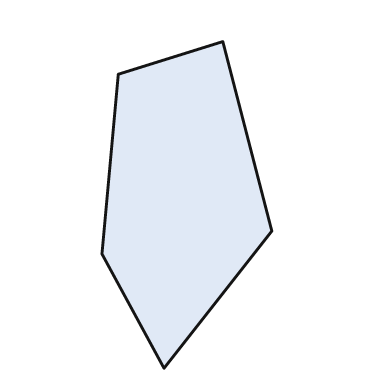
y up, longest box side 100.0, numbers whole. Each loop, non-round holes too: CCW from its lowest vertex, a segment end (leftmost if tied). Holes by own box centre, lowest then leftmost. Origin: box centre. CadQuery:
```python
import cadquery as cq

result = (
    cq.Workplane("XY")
    .moveTo(-7.0, -50.0)
    .lineTo(26.0, -8.0)
    .lineTo(11.0, 50.0)
    .lineTo(-21.0, 40.0)
    .lineTo(-26.0, -15.0)
    .close()
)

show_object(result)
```